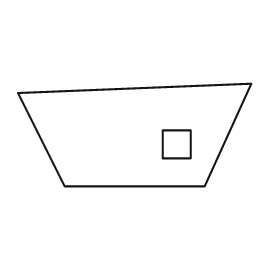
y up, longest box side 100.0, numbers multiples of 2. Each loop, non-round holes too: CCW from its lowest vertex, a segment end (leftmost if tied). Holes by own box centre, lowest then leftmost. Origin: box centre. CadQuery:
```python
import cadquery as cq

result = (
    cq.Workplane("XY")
    .moveTo(-30.0, -22.0)
    .lineTo(30.0, -22.0)
    .lineTo(50.0, 22.0)
    .lineTo(-50.0, 18.0)
    .close()
    .moveTo(12.0, -10.0)
    .lineTo(24.0, -10.0)
    .lineTo(24.0, 2.0)
    .lineTo(12.0, 2.0)
    .close()
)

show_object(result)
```